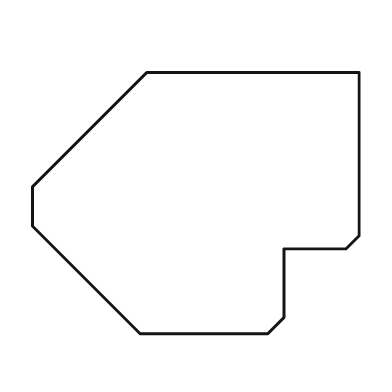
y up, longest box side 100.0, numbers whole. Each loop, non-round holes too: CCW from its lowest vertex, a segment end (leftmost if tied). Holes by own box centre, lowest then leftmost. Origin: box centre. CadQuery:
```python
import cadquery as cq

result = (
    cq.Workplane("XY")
    .moveTo(-17.0, -40.0)
    .lineTo(22.0, -40.0)
    .lineTo(27.0, -35.0)
    .lineTo(27.0, -14.0)
    .lineTo(46.0, -14.0)
    .lineTo(50.0, -10.0)
    .lineTo(50.0, 40.0)
    .lineTo(-15.0, 40.0)
    .lineTo(-50.0, 5.0)
    .lineTo(-50.0, -7.0)
    .close()
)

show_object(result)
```